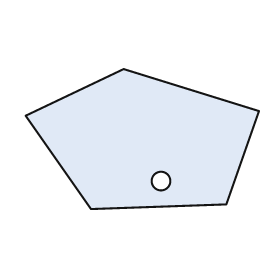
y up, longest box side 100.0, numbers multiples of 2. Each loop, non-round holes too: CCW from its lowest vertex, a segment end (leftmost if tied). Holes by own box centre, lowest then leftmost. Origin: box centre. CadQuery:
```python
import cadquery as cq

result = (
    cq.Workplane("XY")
    .moveTo(-22.0, -30.0)
    .lineTo(36.0, -28.0)
    .lineTo(50.0, 12.0)
    .lineTo(-8.0, 30.0)
    .lineTo(-50.0, 10.0)
    .close()
    .moveTo(8.0, -18.0)
    .circle(4.0)
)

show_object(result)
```